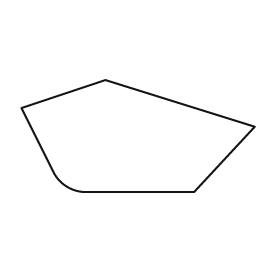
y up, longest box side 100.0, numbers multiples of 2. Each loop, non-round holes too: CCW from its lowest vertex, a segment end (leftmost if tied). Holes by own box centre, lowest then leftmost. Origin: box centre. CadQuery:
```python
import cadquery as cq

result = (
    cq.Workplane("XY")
    .moveTo(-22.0, -24.0)
    .lineTo(24.0, -24.0)
    .lineTo(50.0, 4.0)
    .lineTo(-14.0, 24.0)
    .lineTo(-50.0, 12.0)
    .lineTo(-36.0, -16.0)
    .threePointArc((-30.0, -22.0), (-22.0, -24.0))
    .close()
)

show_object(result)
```